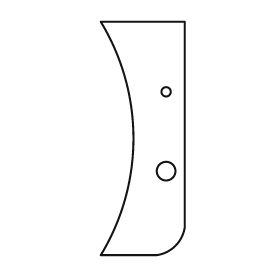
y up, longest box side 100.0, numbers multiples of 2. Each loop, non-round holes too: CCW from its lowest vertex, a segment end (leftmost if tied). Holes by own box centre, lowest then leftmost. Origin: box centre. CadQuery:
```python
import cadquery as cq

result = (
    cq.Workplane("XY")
    .moveTo(-18.0, -50.0)
    .lineTo(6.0, -50.0)
    .threePointArc((14.0, -46.0), (18.0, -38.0))
    .lineTo(18.0, 50.0)
    .lineTo(-18.0, 50.0)
    .threePointArc((-4.0, 0.0), (-18.0, -50.0))
    .close()
    .moveTo(10.0, -14.0)
    .circle(4.0)
    .moveTo(10.0, 20.0)
    .circle(2.0)
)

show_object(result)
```